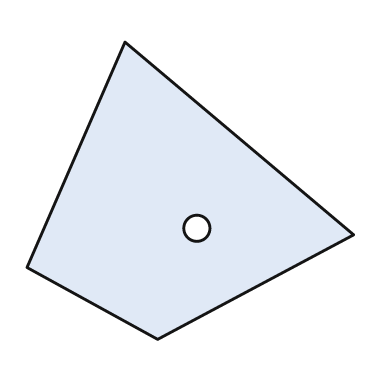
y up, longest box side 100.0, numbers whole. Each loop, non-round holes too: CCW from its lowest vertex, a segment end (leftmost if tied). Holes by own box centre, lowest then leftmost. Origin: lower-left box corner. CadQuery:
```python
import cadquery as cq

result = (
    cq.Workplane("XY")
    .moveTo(40.0, 0.0)
    .lineTo(100.0, 32.0)
    .lineTo(30.0, 91.0)
    .lineTo(0.0, 22.0)
    .close()
    .moveTo(52.0, 34.0)
    .circle(4.0)
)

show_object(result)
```